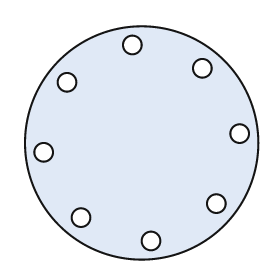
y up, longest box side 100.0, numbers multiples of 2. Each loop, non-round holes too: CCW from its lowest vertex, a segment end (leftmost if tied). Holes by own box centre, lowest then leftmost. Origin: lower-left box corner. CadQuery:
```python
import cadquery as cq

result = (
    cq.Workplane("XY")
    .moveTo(50.0, 50.0)
    .circle(50.0)
    .moveTo(54.0, 8.0)
    .circle(4.0)
    .moveTo(24.0, 18.0)
    .circle(4.0)
    .moveTo(82.0, 24.0)
    .circle(4.0)
    .moveTo(8.0, 46.0)
    .circle(4.0)
    .moveTo(92.0, 54.0)
    .circle(4.0)
    .moveTo(18.0, 76.0)
    .circle(4.0)
    .moveTo(76.0, 82.0)
    .circle(4.0)
    .moveTo(46.0, 92.0)
    .circle(4.0)
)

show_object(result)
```